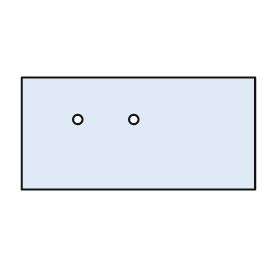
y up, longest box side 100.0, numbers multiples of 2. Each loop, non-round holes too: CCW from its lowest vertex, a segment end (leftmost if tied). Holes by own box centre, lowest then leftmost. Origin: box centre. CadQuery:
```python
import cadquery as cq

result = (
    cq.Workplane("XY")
    .moveTo(-50.0, -24.0)
    .lineTo(50.0, -24.0)
    .lineTo(50.0, 24.0)
    .lineTo(-50.0, 24.0)
    .close()
    .moveTo(-26.0, 6.0)
    .circle(2.0)
    .moveTo(-2.0, 6.0)
    .circle(2.0)
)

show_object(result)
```